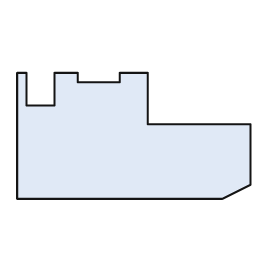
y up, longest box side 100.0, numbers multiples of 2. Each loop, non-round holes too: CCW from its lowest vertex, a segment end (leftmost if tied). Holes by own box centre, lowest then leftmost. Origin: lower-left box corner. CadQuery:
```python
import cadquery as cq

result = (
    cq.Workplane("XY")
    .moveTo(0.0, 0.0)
    .lineTo(88.0, 0.0)
    .lineTo(100.0, 6.0)
    .lineTo(100.0, 32.0)
    .lineTo(56.0, 32.0)
    .lineTo(56.0, 54.0)
    .lineTo(44.0, 54.0)
    .lineTo(44.0, 50.0)
    .lineTo(26.0, 50.0)
    .lineTo(26.0, 54.0)
    .lineTo(16.0, 54.0)
    .lineTo(16.0, 40.0)
    .lineTo(4.0, 40.0)
    .lineTo(4.0, 54.0)
    .lineTo(0.0, 54.0)
    .close()
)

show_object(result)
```